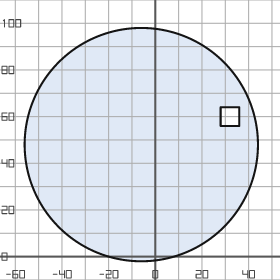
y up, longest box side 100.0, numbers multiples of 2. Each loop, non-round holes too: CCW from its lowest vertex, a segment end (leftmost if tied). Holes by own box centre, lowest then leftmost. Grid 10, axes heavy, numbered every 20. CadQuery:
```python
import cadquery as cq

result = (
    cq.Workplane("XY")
    .moveTo(-6.0, 48.0)
    .circle(50.0)
    .moveTo(28.0, 56.0)
    .lineTo(36.0, 56.0)
    .lineTo(36.0, 64.0)
    .lineTo(28.0, 64.0)
    .close()
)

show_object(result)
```